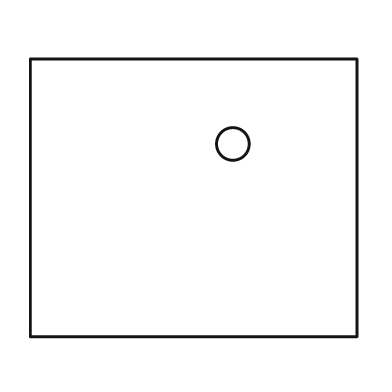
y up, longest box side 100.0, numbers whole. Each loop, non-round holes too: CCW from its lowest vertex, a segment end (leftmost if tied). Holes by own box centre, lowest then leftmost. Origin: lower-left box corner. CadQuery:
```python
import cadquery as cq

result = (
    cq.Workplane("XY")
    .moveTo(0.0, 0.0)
    .lineTo(100.0, 0.0)
    .lineTo(100.0, 85.0)
    .lineTo(0.0, 85.0)
    .close()
    .moveTo(62.0, 59.0)
    .circle(5.0)
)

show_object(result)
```